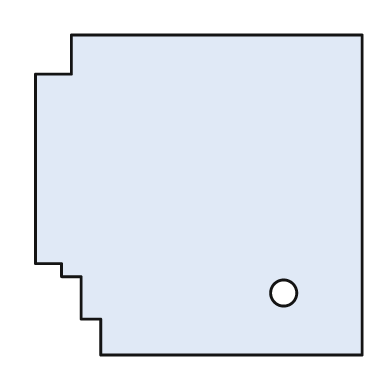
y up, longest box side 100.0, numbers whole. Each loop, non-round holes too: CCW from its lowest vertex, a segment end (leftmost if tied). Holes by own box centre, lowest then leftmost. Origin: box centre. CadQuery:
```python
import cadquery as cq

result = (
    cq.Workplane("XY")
    .moveTo(-30.0, -49.0)
    .lineTo(50.0, -49.0)
    .lineTo(50.0, 49.0)
    .lineTo(-39.0, 49.0)
    .lineTo(-39.0, 37.0)
    .lineTo(-50.0, 37.0)
    .lineTo(-50.0, -21.0)
    .lineTo(-42.0, -21.0)
    .lineTo(-42.0, -25.0)
    .lineTo(-36.0, -25.0)
    .lineTo(-36.0, -38.0)
    .lineTo(-30.0, -38.0)
    .close()
    .moveTo(26.0, -30.0)
    .circle(4.0)
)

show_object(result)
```